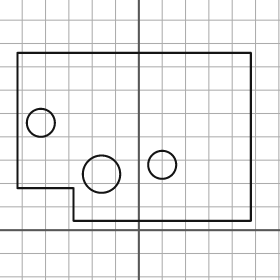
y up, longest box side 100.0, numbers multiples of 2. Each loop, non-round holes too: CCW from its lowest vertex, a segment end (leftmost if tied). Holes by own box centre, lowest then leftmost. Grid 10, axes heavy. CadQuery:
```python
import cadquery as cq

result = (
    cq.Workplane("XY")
    .moveTo(-28.0, 4.0)
    .lineTo(48.0, 4.0)
    .lineTo(48.0, 76.0)
    .lineTo(-52.0, 76.0)
    .lineTo(-52.0, 18.0)
    .lineTo(-28.0, 18.0)
    .close()
    .moveTo(-16.0, 24.0)
    .circle(8.0)
    .moveTo(10.0, 28.0)
    .circle(6.0)
    .moveTo(-42.0, 46.0)
    .circle(6.0)
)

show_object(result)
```